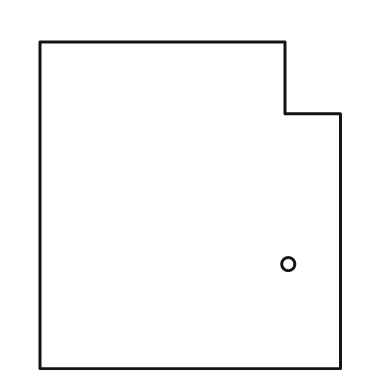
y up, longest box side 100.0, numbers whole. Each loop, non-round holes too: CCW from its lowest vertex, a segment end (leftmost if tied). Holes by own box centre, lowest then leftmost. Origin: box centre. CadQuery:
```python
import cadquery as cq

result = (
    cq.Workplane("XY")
    .moveTo(-46.0, -50.0)
    .lineTo(46.0, -50.0)
    .lineTo(46.0, 28.0)
    .lineTo(29.0, 28.0)
    .lineTo(29.0, 50.0)
    .lineTo(-46.0, 50.0)
    .close()
    .moveTo(30.0, -18.0)
    .circle(2.0)
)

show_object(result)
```